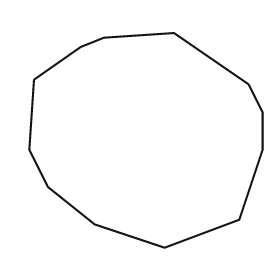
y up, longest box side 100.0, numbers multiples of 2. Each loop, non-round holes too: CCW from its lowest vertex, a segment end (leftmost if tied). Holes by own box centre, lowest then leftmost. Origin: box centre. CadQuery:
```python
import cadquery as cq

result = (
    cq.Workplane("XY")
    .moveTo(8.0, -46.0)
    .lineTo(40.0, -34.0)
    .lineTo(50.0, -4.0)
    .lineTo(50.0, 12.0)
    .lineTo(44.0, 24.0)
    .lineTo(12.0, 46.0)
    .lineTo(-18.0, 44.0)
    .lineTo(-28.0, 40.0)
    .lineTo(-48.0, 26.0)
    .lineTo(-50.0, -4.0)
    .lineTo(-42.0, -20.0)
    .lineTo(-22.0, -36.0)
    .close()
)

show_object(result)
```